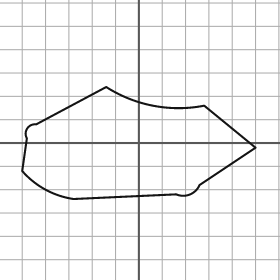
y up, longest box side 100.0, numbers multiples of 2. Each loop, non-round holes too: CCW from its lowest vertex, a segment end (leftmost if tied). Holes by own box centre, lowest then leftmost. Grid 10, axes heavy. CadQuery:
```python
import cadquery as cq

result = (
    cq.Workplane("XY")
    .moveTo(-28.0, -24.0)
    .lineTo(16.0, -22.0)
    .threePointArc((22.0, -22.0), (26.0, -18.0))
    .lineTo(50.0, -2.0)
    .lineTo(28.0, 16.0)
    .threePointArc((6.0, 16.0), (-14.0, 24.0))
    .lineTo(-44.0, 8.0)
    .threePointArc((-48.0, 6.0), (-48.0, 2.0))
    .lineTo(-50.0, -12.0)
    .threePointArc((-40.0, -20.0), (-28.0, -24.0))
    .close()
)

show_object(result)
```